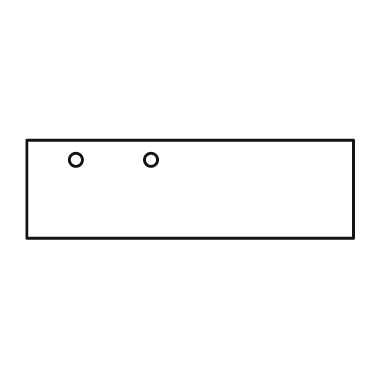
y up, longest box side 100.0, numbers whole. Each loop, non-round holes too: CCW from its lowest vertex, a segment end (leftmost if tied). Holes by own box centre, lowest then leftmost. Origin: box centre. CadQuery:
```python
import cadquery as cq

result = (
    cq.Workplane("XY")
    .moveTo(-50.0, -15.0)
    .lineTo(50.0, -15.0)
    .lineTo(50.0, 15.0)
    .lineTo(-50.0, 15.0)
    .close()
    .moveTo(-35.0, 9.0)
    .circle(2.0)
    .moveTo(-12.0, 9.0)
    .circle(2.0)
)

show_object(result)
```